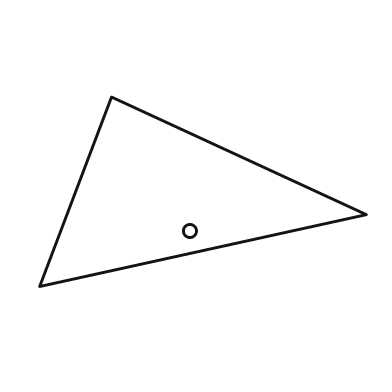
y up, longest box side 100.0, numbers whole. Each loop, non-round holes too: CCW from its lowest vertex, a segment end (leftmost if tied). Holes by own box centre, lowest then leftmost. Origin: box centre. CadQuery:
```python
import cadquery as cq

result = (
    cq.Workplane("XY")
    .moveTo(-50.0, -29.0)
    .lineTo(50.0, -7.0)
    .lineTo(-28.0, 29.0)
    .close()
    .moveTo(-4.0, -12.0)
    .circle(2.0)
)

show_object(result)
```